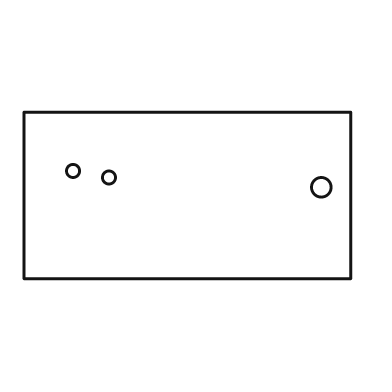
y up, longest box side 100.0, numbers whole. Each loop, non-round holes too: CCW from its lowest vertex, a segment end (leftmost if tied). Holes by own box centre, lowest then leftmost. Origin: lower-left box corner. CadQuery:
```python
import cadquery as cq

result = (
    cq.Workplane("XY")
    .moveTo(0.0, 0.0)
    .lineTo(100.0, 0.0)
    .lineTo(100.0, 51.0)
    .lineTo(0.0, 51.0)
    .close()
    .moveTo(91.0, 28.0)
    .circle(3.0)
    .moveTo(26.0, 31.0)
    .circle(2.0)
    .moveTo(15.0, 33.0)
    .circle(2.0)
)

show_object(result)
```